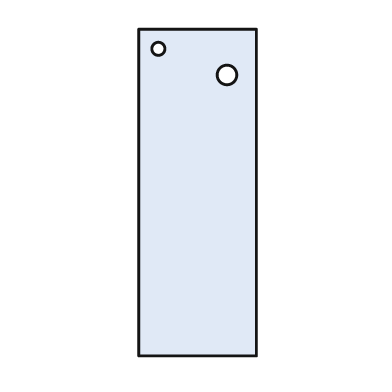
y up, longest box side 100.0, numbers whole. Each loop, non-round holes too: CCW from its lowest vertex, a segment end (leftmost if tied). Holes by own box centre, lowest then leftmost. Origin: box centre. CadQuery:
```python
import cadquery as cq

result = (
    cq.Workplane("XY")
    .moveTo(-18.0, -50.0)
    .lineTo(18.0, -50.0)
    .lineTo(18.0, 50.0)
    .lineTo(-18.0, 50.0)
    .close()
    .moveTo(9.0, 36.0)
    .circle(3.0)
    .moveTo(-12.0, 44.0)
    .circle(2.0)
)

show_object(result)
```